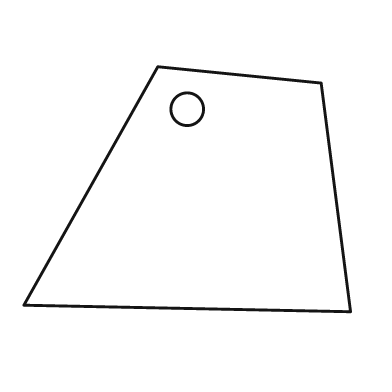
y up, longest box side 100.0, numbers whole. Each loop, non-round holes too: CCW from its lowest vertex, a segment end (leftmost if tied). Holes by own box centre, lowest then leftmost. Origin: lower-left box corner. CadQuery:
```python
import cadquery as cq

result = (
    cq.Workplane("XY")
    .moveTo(100.0, 0.0)
    .lineTo(91.0, 70.0)
    .lineTo(41.0, 75.0)
    .lineTo(0.0, 2.0)
    .close()
    .moveTo(50.0, 62.0)
    .circle(5.0)
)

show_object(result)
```